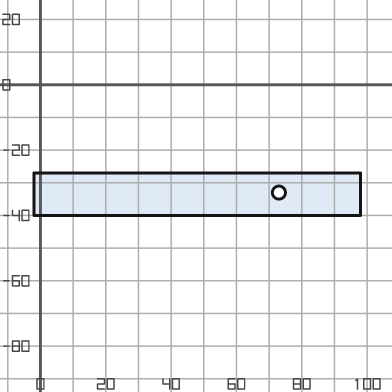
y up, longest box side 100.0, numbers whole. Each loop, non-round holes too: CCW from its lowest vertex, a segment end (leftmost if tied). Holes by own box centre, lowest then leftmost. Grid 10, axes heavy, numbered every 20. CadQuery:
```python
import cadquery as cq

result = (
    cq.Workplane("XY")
    .moveTo(-2.0, -40.0)
    .lineTo(98.0, -40.0)
    .lineTo(98.0, -27.0)
    .lineTo(-2.0, -27.0)
    .close()
    .moveTo(73.0, -33.0)
    .circle(2.0)
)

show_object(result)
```